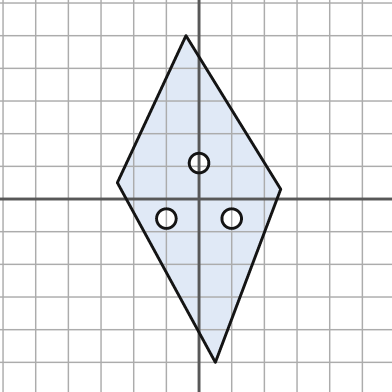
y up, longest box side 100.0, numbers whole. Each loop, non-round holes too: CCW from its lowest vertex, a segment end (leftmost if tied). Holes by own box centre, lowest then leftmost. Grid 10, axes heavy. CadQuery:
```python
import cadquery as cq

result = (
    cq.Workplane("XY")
    .moveTo(5.0, -50.0)
    .lineTo(25.0, 3.0)
    .lineTo(-4.0, 50.0)
    .lineTo(-25.0, 5.0)
    .close()
    .moveTo(-10.0, -6.0)
    .circle(3.0)
    .moveTo(10.0, -6.0)
    .circle(3.0)
    .moveTo(0.0, 11.0)
    .circle(3.0)
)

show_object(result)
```